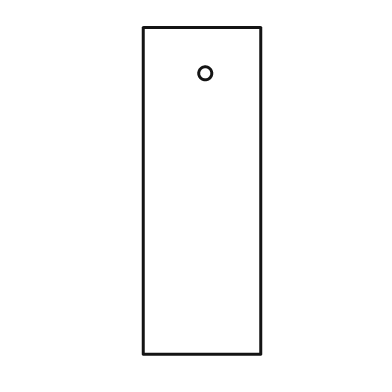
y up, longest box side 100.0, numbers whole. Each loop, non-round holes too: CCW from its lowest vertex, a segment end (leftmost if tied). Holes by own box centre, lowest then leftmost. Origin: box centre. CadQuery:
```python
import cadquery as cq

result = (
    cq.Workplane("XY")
    .moveTo(-18.0, -50.0)
    .lineTo(18.0, -50.0)
    .lineTo(18.0, 50.0)
    .lineTo(-18.0, 50.0)
    .close()
    .moveTo(1.0, 36.0)
    .circle(2.0)
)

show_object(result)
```